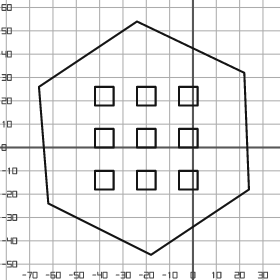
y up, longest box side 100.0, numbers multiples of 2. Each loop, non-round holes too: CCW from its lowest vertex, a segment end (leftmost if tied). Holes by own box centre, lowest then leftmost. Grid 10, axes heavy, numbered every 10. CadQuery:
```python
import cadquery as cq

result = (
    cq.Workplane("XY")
    .moveTo(-18.0, -46.0)
    .lineTo(24.0, -18.0)
    .lineTo(22.0, 32.0)
    .lineTo(-24.0, 54.0)
    .lineTo(-66.0, 26.0)
    .lineTo(-62.0, -24.0)
    .close()
    .moveTo(-42.0, -18.0)
    .lineTo(-34.0, -18.0)
    .lineTo(-34.0, -10.0)
    .lineTo(-42.0, -10.0)
    .close()
    .moveTo(-24.0, -18.0)
    .lineTo(-16.0, -18.0)
    .lineTo(-16.0, -10.0)
    .lineTo(-24.0, -10.0)
    .close()
    .moveTo(-6.0, -18.0)
    .lineTo(2.0, -18.0)
    .lineTo(2.0, -10.0)
    .lineTo(-6.0, -10.0)
    .close()
    .moveTo(-42.0, 0.0)
    .lineTo(-34.0, 0.0)
    .lineTo(-34.0, 8.0)
    .lineTo(-42.0, 8.0)
    .close()
    .moveTo(-24.0, 0.0)
    .lineTo(-16.0, 0.0)
    .lineTo(-16.0, 8.0)
    .lineTo(-24.0, 8.0)
    .close()
    .moveTo(-6.0, 0.0)
    .lineTo(2.0, 0.0)
    .lineTo(2.0, 8.0)
    .lineTo(-6.0, 8.0)
    .close()
    .moveTo(-42.0, 18.0)
    .lineTo(-34.0, 18.0)
    .lineTo(-34.0, 26.0)
    .lineTo(-42.0, 26.0)
    .close()
    .moveTo(-24.0, 18.0)
    .lineTo(-16.0, 18.0)
    .lineTo(-16.0, 26.0)
    .lineTo(-24.0, 26.0)
    .close()
    .moveTo(-6.0, 18.0)
    .lineTo(2.0, 18.0)
    .lineTo(2.0, 26.0)
    .lineTo(-6.0, 26.0)
    .close()
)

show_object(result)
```